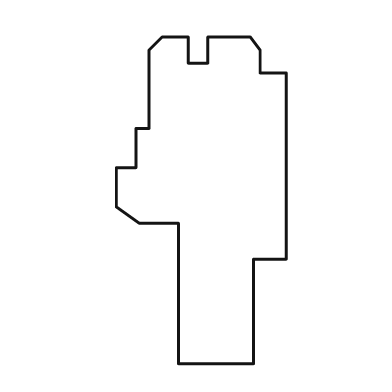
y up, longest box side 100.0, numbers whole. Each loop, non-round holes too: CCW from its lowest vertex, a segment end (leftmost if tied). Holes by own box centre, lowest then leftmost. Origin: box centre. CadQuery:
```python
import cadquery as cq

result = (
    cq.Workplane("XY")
    .moveTo(-7.0, -50.0)
    .lineTo(16.0, -50.0)
    .lineTo(16.0, -18.0)
    .lineTo(26.0, -18.0)
    .lineTo(26.0, 39.0)
    .lineTo(18.0, 39.0)
    .lineTo(18.0, 46.0)
    .lineTo(15.0, 50.0)
    .lineTo(2.0, 50.0)
    .lineTo(2.0, 42.0)
    .lineTo(-4.0, 42.0)
    .lineTo(-4.0, 50.0)
    .lineTo(-12.0, 50.0)
    .lineTo(-16.0, 46.0)
    .lineTo(-16.0, 22.0)
    .lineTo(-20.0, 22.0)
    .lineTo(-20.0, 10.0)
    .lineTo(-26.0, 10.0)
    .lineTo(-26.0, -2.0)
    .lineTo(-19.0, -7.0)
    .lineTo(-7.0, -7.0)
    .close()
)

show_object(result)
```